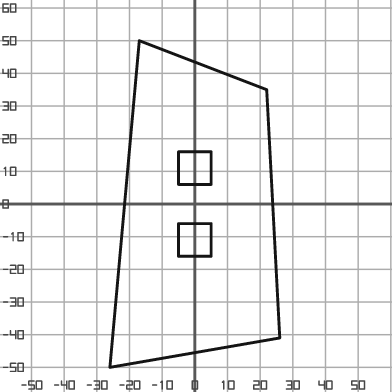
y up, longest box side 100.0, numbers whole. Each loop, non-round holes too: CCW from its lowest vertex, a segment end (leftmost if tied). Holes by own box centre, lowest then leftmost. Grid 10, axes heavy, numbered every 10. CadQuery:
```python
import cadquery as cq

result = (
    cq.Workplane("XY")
    .moveTo(-26.0, -50.0)
    .lineTo(26.0, -41.0)
    .lineTo(22.0, 35.0)
    .lineTo(-17.0, 50.0)
    .close()
    .moveTo(-5.0, -16.0)
    .lineTo(5.0, -16.0)
    .lineTo(5.0, -6.0)
    .lineTo(-5.0, -6.0)
    .close()
    .moveTo(-5.0, 6.0)
    .lineTo(5.0, 6.0)
    .lineTo(5.0, 16.0)
    .lineTo(-5.0, 16.0)
    .close()
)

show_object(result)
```